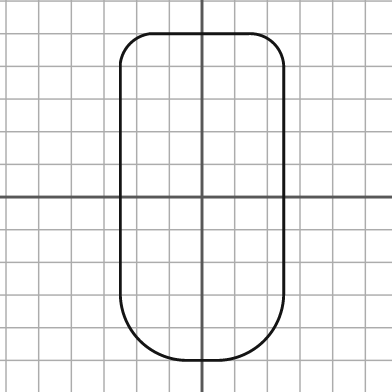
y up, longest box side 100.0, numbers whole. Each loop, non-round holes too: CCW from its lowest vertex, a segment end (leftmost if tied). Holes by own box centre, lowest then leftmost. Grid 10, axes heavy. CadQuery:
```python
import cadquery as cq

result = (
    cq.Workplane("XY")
    .moveTo(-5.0, -50.0)
    .lineTo(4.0, -50.0)
    .threePointArc((19.0, -44.0), (25.0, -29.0))
    .lineTo(25.0, 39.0)
    .threePointArc((22.0, 47.0), (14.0, 50.0))
    .lineTo(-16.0, 50.0)
    .threePointArc((-22.0, 47.0), (-25.0, 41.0))
    .lineTo(-25.0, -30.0)
    .threePointArc((-19.0, -44.0), (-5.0, -50.0))
    .close()
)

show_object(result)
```